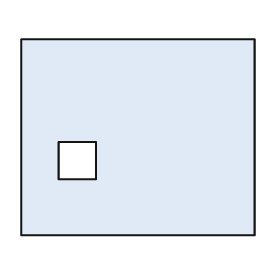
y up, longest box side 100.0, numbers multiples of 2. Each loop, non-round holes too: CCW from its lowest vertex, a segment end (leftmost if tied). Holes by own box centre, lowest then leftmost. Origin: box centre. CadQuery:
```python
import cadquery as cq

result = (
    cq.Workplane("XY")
    .moveTo(-50.0, -42.0)
    .lineTo(50.0, -42.0)
    .lineTo(50.0, 42.0)
    .lineTo(-50.0, 42.0)
    .close()
    .moveTo(-34.0, -18.0)
    .lineTo(-18.0, -18.0)
    .lineTo(-18.0, -2.0)
    .lineTo(-34.0, -2.0)
    .close()
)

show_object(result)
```